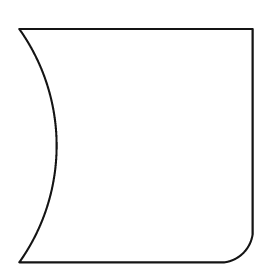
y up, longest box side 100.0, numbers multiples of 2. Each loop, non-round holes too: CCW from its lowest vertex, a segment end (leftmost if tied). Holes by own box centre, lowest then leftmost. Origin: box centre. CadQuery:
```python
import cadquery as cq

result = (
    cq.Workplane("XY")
    .moveTo(-50.0, -50.0)
    .lineTo(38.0, -50.0)
    .threePointArc((46.0, -46.0), (50.0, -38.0))
    .lineTo(50.0, 50.0)
    .lineTo(-50.0, 50.0)
    .threePointArc((-34.0, 0.0), (-50.0, -50.0))
    .close()
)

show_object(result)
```